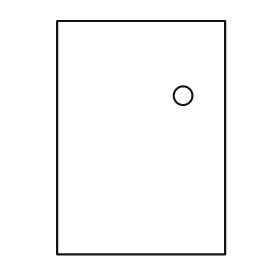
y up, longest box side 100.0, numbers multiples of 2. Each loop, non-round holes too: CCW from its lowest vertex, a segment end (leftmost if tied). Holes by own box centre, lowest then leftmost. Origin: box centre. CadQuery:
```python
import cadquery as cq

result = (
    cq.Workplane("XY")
    .moveTo(-36.0, -50.0)
    .lineTo(36.0, -50.0)
    .lineTo(36.0, 50.0)
    .lineTo(-36.0, 50.0)
    .close()
    .moveTo(18.0, 18.0)
    .circle(4.0)
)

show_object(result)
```